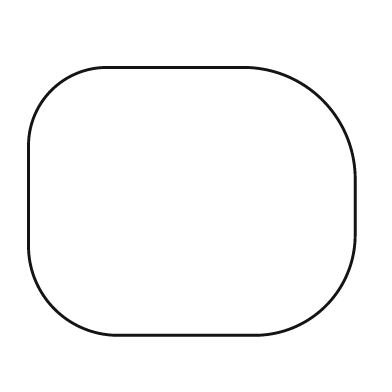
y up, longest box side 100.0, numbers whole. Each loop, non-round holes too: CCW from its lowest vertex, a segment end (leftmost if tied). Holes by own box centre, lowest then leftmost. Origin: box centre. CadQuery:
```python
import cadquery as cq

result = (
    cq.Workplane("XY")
    .moveTo(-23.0, -41.0)
    .lineTo(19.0, -41.0)
    .threePointArc((41.0, -32.0), (50.0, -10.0))
    .lineTo(50.0, 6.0)
    .threePointArc((40.0, 31.0), (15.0, 41.0))
    .lineTo(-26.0, 41.0)
    .threePointArc((-43.0, 34.0), (-50.0, 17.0))
    .lineTo(-50.0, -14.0)
    .threePointArc((-42.0, -33.0), (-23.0, -41.0))
    .close()
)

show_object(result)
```